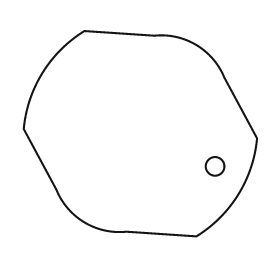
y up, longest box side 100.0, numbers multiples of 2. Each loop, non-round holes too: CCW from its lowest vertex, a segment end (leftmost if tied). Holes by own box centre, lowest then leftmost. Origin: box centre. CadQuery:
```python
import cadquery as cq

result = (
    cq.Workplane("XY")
    .moveTo(24.0, -44.0)
    .threePointArc((42.0, -26.0), (50.0, -2.0))
    .lineTo(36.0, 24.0)
    .threePointArc((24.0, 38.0), (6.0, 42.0))
    .lineTo(-24.0, 44.0)
    .threePointArc((-42.0, 26.0), (-50.0, 2.0))
    .lineTo(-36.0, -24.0)
    .threePointArc((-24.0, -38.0), (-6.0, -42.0))
    .close()
    .moveTo(32.0, -14.0)
    .circle(4.0)
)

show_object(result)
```